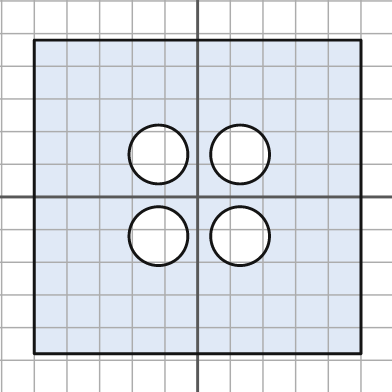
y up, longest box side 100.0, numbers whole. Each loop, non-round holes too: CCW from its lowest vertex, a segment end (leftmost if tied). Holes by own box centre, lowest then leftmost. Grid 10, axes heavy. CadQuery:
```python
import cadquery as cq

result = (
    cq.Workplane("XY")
    .moveTo(-50.0, -48.0)
    .lineTo(50.0, -48.0)
    .lineTo(50.0, 48.0)
    .lineTo(-50.0, 48.0)
    .close()
    .moveTo(-12.0, -12.0)
    .circle(9.0)
    .moveTo(13.0, -12.0)
    .circle(9.0)
    .moveTo(-12.0, 13.0)
    .circle(9.0)
    .moveTo(13.0, 13.0)
    .circle(9.0)
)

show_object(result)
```